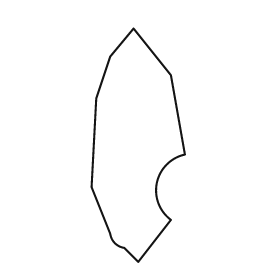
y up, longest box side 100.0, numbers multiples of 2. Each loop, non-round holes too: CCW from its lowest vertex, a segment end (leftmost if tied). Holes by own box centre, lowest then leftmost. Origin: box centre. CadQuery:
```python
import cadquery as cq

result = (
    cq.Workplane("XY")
    .moveTo(0.0, -50.0)
    .lineTo(14.0, -32.0)
    .threePointArc((8.0, -16.0), (20.0, -4.0))
    .lineTo(14.0, 30.0)
    .lineTo(-2.0, 50.0)
    .lineTo(-12.0, 38.0)
    .lineTo(-18.0, 20.0)
    .lineTo(-20.0, -18.0)
    .lineTo(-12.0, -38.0)
    .threePointArc((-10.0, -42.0), (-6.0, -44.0))
    .close()
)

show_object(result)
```